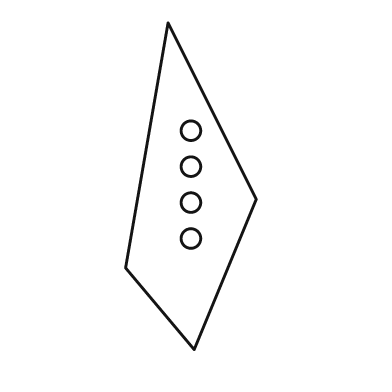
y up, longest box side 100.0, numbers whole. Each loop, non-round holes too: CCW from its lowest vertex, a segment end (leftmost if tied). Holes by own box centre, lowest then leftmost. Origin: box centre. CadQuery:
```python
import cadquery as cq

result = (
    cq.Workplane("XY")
    .moveTo(1.0, -50.0)
    .lineTo(20.0, -4.0)
    .lineTo(-7.0, 50.0)
    .lineTo(-20.0, -25.0)
    .close()
    .moveTo(0.0, -16.0)
    .circle(3.0)
    .moveTo(0.0, -5.0)
    .circle(3.0)
    .moveTo(0.0, 6.0)
    .circle(3.0)
    .moveTo(0.0, 17.0)
    .circle(3.0)
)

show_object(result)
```